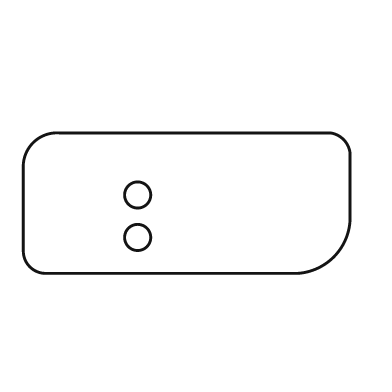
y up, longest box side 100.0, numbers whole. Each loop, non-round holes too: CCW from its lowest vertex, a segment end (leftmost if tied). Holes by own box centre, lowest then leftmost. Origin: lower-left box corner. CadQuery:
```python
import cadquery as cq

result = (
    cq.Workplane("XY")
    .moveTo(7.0, 0.0)
    .lineTo(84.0, 0.0)
    .threePointArc((95.0, 5.0), (100.0, 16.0))
    .lineTo(100.0, 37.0)
    .threePointArc((98.0, 41.0), (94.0, 43.0))
    .lineTo(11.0, 43.0)
    .threePointArc((3.0, 40.0), (0.0, 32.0))
    .lineTo(0.0, 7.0)
    .threePointArc((2.0, 2.0), (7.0, 0.0))
    .close()
    .moveTo(35.0, 11.0)
    .circle(4.0)
    .moveTo(35.0, 24.0)
    .circle(4.0)
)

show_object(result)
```